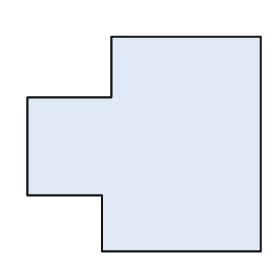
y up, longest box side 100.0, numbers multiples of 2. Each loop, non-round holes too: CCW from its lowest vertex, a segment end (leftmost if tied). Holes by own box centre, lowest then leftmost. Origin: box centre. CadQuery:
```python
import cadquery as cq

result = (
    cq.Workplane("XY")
    .moveTo(-18.0, -46.0)
    .lineTo(50.0, -46.0)
    .lineTo(50.0, 46.0)
    .lineTo(-14.0, 46.0)
    .lineTo(-14.0, 20.0)
    .lineTo(-50.0, 20.0)
    .lineTo(-50.0, -22.0)
    .lineTo(-18.0, -22.0)
    .close()
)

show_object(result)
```